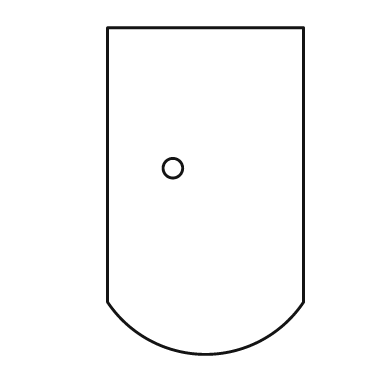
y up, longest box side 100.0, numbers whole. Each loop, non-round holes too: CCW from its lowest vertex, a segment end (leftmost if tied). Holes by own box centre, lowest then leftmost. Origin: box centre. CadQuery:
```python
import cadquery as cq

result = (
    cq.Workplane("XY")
    .moveTo(-30.0, -34.0)
    .threePointArc((0.0, -50.0), (30.0, -34.0))
    .lineTo(30.0, 50.0)
    .lineTo(-30.0, 50.0)
    .close()
    .moveTo(-10.0, 7.0)
    .circle(3.0)
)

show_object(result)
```